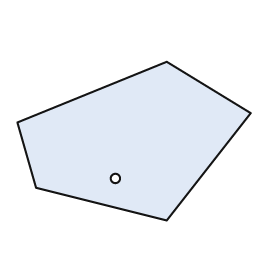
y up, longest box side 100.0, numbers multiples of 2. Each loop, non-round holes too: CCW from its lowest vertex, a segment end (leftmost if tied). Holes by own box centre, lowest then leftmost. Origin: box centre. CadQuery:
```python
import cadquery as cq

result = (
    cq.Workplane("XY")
    .moveTo(14.0, -34.0)
    .lineTo(50.0, 12.0)
    .lineTo(14.0, 34.0)
    .lineTo(-50.0, 8.0)
    .lineTo(-42.0, -20.0)
    .close()
    .moveTo(-8.0, -16.0)
    .circle(2.0)
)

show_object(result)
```